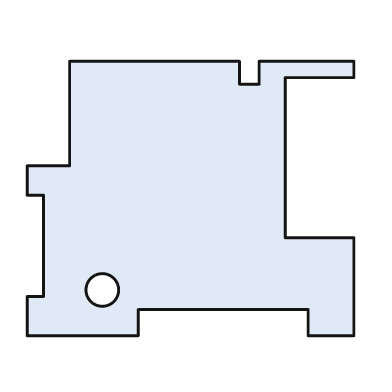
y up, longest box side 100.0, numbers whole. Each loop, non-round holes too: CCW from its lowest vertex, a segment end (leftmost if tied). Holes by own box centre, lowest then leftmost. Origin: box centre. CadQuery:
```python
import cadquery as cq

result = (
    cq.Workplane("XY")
    .moveTo(-50.0, -42.0)
    .lineTo(-16.0, -42.0)
    .lineTo(-16.0, -34.0)
    .lineTo(36.0, -34.0)
    .lineTo(36.0, -42.0)
    .lineTo(50.0, -42.0)
    .lineTo(50.0, -12.0)
    .lineTo(29.0, -12.0)
    .lineTo(29.0, 37.0)
    .lineTo(50.0, 37.0)
    .lineTo(50.0, 42.0)
    .lineTo(21.0, 42.0)
    .lineTo(21.0, 35.0)
    .lineTo(15.0, 35.0)
    .lineTo(15.0, 42.0)
    .lineTo(-37.0, 42.0)
    .lineTo(-37.0, 10.0)
    .lineTo(-50.0, 10.0)
    .lineTo(-50.0, 1.0)
    .lineTo(-45.0, 1.0)
    .lineTo(-45.0, -30.0)
    .lineTo(-50.0, -30.0)
    .close()
    .moveTo(-27.0, -28.0)
    .circle(5.0)
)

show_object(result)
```